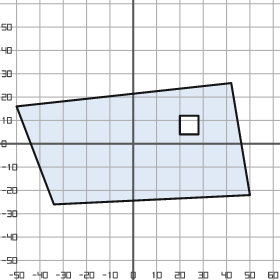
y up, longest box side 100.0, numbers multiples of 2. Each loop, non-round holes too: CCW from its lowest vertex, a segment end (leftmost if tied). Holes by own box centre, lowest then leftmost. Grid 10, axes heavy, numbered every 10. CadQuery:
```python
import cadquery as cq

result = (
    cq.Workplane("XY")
    .moveTo(-34.0, -26.0)
    .lineTo(50.0, -22.0)
    .lineTo(42.0, 26.0)
    .lineTo(-50.0, 16.0)
    .close()
    .moveTo(20.0, 4.0)
    .lineTo(28.0, 4.0)
    .lineTo(28.0, 12.0)
    .lineTo(20.0, 12.0)
    .close()
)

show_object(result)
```